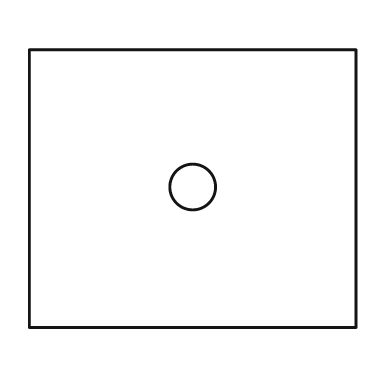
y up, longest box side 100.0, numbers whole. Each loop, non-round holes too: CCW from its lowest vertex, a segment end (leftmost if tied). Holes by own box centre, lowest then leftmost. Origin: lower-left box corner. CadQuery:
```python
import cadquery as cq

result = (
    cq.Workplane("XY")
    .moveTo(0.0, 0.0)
    .lineTo(100.0, 0.0)
    .lineTo(100.0, 85.0)
    .lineTo(0.0, 85.0)
    .close()
    .moveTo(50.0, 43.0)
    .circle(7.0)
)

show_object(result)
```